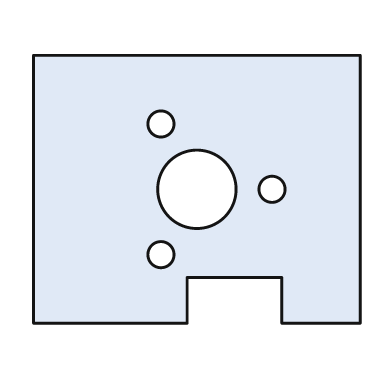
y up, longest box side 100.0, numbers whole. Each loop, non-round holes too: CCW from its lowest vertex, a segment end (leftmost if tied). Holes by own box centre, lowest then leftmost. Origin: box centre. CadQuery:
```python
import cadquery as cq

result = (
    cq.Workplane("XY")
    .moveTo(-50.0, -41.0)
    .lineTo(-3.0, -41.0)
    .lineTo(-3.0, -27.0)
    .lineTo(26.0, -27.0)
    .lineTo(26.0, -41.0)
    .lineTo(50.0, -41.0)
    .lineTo(50.0, 41.0)
    .lineTo(-50.0, 41.0)
    .close()
    .moveTo(-11.0, -20.0)
    .circle(4.0)
    .moveTo(0.0, 0.0)
    .circle(12.0)
    .moveTo(23.0, 0.0)
    .circle(4.0)
    .moveTo(-11.0, 20.0)
    .circle(4.0)
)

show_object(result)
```